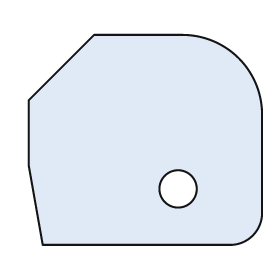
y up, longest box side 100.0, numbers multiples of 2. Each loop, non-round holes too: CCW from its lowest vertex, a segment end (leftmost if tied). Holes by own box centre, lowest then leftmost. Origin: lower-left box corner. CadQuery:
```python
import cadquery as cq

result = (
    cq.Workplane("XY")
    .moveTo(6.0, 0.0)
    .lineTo(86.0, 0.0)
    .threePointArc((96.0, 4.0), (100.0, 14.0))
    .lineTo(100.0, 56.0)
    .threePointArc((90.0, 80.0), (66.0, 90.0))
    .lineTo(28.0, 90.0)
    .lineTo(0.0, 62.0)
    .lineTo(0.0, 34.0)
    .close()
    .moveTo(64.0, 24.0)
    .circle(8.0)
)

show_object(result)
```